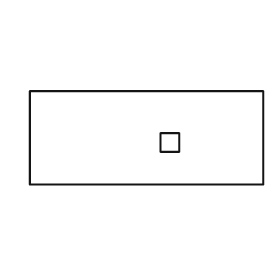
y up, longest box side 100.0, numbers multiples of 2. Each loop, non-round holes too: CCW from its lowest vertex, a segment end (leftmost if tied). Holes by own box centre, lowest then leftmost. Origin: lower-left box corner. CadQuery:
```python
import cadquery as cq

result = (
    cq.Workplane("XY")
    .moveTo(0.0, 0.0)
    .lineTo(100.0, 0.0)
    .lineTo(100.0, 40.0)
    .lineTo(0.0, 40.0)
    .close()
    .moveTo(56.0, 14.0)
    .lineTo(64.0, 14.0)
    .lineTo(64.0, 22.0)
    .lineTo(56.0, 22.0)
    .close()
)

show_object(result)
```